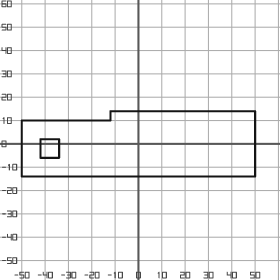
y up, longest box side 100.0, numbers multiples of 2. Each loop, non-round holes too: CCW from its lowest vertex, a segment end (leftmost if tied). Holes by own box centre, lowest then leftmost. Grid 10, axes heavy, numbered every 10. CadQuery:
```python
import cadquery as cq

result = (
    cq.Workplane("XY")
    .moveTo(-50.0, -14.0)
    .lineTo(50.0, -14.0)
    .lineTo(50.0, 14.0)
    .lineTo(-12.0, 14.0)
    .lineTo(-12.0, 10.0)
    .lineTo(-50.0, 10.0)
    .close()
    .moveTo(-42.0, -6.0)
    .lineTo(-34.0, -6.0)
    .lineTo(-34.0, 2.0)
    .lineTo(-42.0, 2.0)
    .close()
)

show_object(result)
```